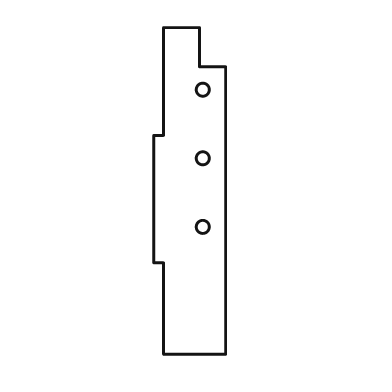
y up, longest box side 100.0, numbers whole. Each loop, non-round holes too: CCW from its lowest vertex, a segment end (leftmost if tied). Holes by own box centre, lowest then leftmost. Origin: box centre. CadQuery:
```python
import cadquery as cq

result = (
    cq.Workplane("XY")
    .moveTo(-8.0, -50.0)
    .lineTo(11.0, -50.0)
    .lineTo(11.0, 38.0)
    .lineTo(3.0, 38.0)
    .lineTo(3.0, 50.0)
    .lineTo(-8.0, 50.0)
    .lineTo(-8.0, 17.0)
    .lineTo(-11.0, 17.0)
    .lineTo(-11.0, -22.0)
    .lineTo(-8.0, -22.0)
    .close()
    .moveTo(4.0, -11.0)
    .circle(2.0)
    .moveTo(4.0, 10.0)
    .circle(2.0)
    .moveTo(4.0, 31.0)
    .circle(2.0)
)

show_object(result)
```